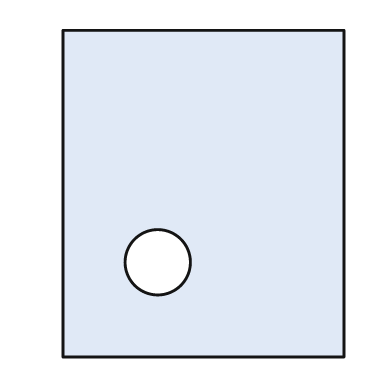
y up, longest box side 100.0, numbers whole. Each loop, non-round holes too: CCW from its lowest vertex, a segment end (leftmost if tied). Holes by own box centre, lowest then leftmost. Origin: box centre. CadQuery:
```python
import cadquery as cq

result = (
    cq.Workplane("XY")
    .moveTo(-43.0, -50.0)
    .lineTo(43.0, -50.0)
    .lineTo(43.0, 50.0)
    .lineTo(-43.0, 50.0)
    .close()
    .moveTo(-14.0, -21.0)
    .circle(10.0)
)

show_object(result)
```